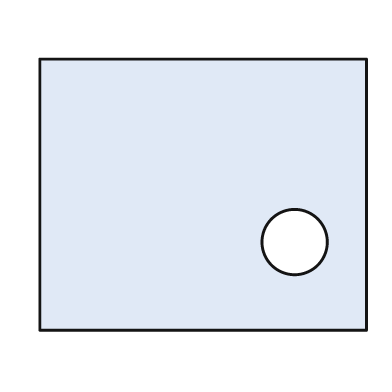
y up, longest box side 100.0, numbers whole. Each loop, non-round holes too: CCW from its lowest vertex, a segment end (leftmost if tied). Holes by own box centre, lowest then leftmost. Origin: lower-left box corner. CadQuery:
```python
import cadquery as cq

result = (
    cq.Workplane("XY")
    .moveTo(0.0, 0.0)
    .lineTo(100.0, 0.0)
    .lineTo(100.0, 83.0)
    .lineTo(0.0, 83.0)
    .close()
    .moveTo(78.0, 27.0)
    .circle(10.0)
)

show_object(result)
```